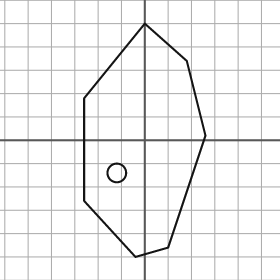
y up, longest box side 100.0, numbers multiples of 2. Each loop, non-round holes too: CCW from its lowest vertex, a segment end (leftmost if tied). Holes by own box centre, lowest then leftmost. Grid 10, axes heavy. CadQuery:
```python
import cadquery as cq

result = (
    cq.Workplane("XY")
    .moveTo(-4.0, -50.0)
    .lineTo(10.0, -46.0)
    .lineTo(26.0, 2.0)
    .lineTo(18.0, 34.0)
    .lineTo(0.0, 50.0)
    .lineTo(-26.0, 18.0)
    .lineTo(-26.0, -26.0)
    .close()
    .moveTo(-12.0, -14.0)
    .circle(4.0)
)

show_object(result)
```